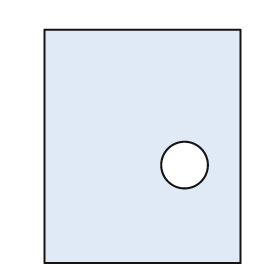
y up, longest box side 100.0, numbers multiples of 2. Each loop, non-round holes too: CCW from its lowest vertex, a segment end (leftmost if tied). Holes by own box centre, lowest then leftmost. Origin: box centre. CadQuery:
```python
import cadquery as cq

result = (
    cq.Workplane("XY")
    .moveTo(-42.0, -50.0)
    .lineTo(42.0, -50.0)
    .lineTo(42.0, 50.0)
    .lineTo(-42.0, 50.0)
    .close()
    .moveTo(18.0, -8.0)
    .circle(10.0)
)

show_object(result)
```